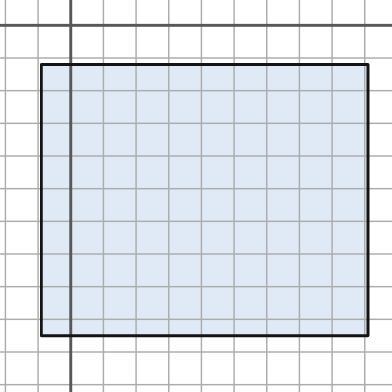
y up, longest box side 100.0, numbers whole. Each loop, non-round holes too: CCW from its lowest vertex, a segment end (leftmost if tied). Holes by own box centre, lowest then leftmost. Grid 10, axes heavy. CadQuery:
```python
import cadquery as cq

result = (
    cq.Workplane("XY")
    .moveTo(-9.0, -95.0)
    .lineTo(91.0, -95.0)
    .lineTo(91.0, -12.0)
    .lineTo(-9.0, -12.0)
    .close()
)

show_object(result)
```